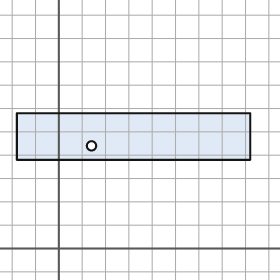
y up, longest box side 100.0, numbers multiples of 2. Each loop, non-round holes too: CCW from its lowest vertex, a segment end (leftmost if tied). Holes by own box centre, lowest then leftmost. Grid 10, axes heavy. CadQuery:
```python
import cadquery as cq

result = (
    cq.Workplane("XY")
    .moveTo(-18.0, 38.0)
    .lineTo(82.0, 38.0)
    .lineTo(82.0, 58.0)
    .lineTo(-18.0, 58.0)
    .close()
    .moveTo(14.0, 44.0)
    .circle(2.0)
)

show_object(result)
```